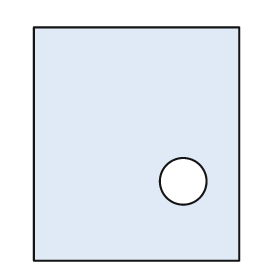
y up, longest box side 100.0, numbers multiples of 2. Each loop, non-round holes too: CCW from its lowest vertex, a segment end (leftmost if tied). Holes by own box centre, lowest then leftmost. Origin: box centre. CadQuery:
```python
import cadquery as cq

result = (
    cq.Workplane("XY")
    .moveTo(-44.0, -50.0)
    .lineTo(44.0, -50.0)
    .lineTo(44.0, 50.0)
    .lineTo(-44.0, 50.0)
    .close()
    .moveTo(20.0, -16.0)
    .circle(10.0)
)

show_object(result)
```